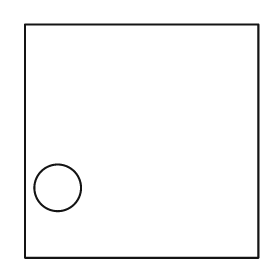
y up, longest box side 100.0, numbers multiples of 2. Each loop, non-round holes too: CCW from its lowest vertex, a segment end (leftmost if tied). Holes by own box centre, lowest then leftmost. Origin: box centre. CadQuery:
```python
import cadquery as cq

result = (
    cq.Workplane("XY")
    .moveTo(-50.0, -50.0)
    .lineTo(50.0, -50.0)
    .lineTo(50.0, 50.0)
    .lineTo(-50.0, 50.0)
    .close()
    .moveTo(-36.0, -20.0)
    .circle(10.0)
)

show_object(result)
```